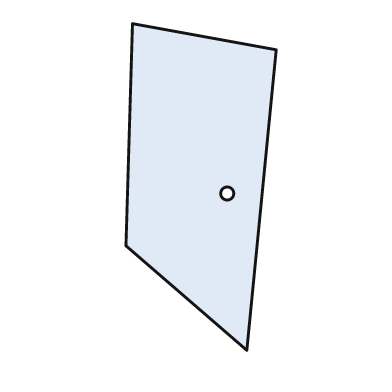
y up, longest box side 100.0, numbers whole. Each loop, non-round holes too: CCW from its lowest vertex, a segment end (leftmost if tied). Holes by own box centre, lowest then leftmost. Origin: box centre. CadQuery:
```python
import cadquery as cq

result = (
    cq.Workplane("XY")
    .moveTo(14.0, -50.0)
    .lineTo(23.0, 42.0)
    .lineTo(-21.0, 50.0)
    .lineTo(-23.0, -18.0)
    .close()
    .moveTo(8.0, -2.0)
    .circle(2.0)
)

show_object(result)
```